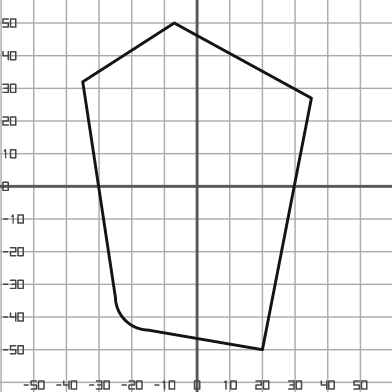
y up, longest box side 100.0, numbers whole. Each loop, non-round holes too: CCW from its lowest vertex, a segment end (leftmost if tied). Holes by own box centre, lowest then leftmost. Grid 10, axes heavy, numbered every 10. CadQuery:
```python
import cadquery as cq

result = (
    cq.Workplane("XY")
    .moveTo(20.0, -50.0)
    .lineTo(35.0, 27.0)
    .lineTo(-7.0, 50.0)
    .lineTo(-35.0, 32.0)
    .lineTo(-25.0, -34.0)
    .threePointArc((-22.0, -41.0), (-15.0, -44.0))
    .close()
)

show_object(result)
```